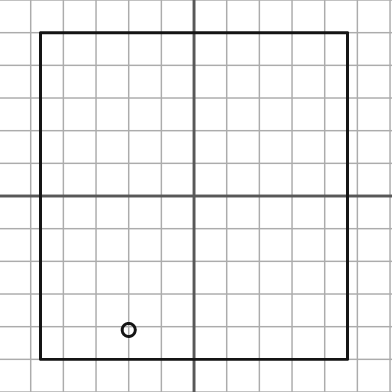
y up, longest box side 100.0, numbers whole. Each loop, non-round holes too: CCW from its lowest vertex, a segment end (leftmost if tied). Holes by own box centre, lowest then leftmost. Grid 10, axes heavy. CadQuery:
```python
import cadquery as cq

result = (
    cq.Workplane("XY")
    .moveTo(-47.0, -50.0)
    .lineTo(47.0, -50.0)
    .lineTo(47.0, 50.0)
    .lineTo(-47.0, 50.0)
    .close()
    .moveTo(-20.0, -41.0)
    .circle(2.0)
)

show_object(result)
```